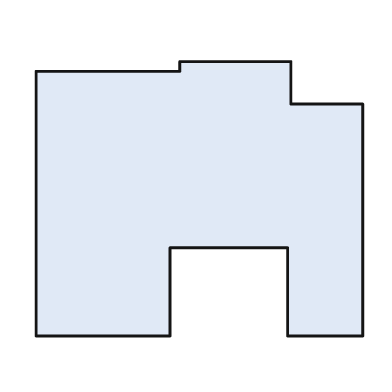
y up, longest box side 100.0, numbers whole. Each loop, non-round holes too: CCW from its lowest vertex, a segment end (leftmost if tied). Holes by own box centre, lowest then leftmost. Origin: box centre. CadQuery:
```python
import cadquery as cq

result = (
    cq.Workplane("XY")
    .moveTo(-50.0, -42.0)
    .lineTo(-9.0, -42.0)
    .lineTo(-9.0, -15.0)
    .lineTo(27.0, -15.0)
    .lineTo(27.0, -42.0)
    .lineTo(50.0, -42.0)
    .lineTo(50.0, 29.0)
    .lineTo(28.0, 29.0)
    .lineTo(28.0, 42.0)
    .lineTo(-6.0, 42.0)
    .lineTo(-6.0, 39.0)
    .lineTo(-50.0, 39.0)
    .close()
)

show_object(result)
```